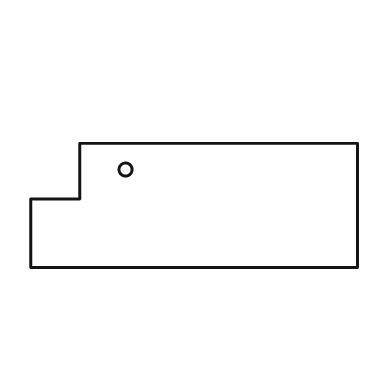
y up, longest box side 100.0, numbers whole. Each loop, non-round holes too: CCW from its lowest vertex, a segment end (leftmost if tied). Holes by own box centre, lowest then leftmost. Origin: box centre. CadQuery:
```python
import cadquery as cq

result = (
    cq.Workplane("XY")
    .moveTo(-50.0, -19.0)
    .lineTo(50.0, -19.0)
    .lineTo(50.0, 19.0)
    .lineTo(-35.0, 19.0)
    .lineTo(-35.0, 2.0)
    .lineTo(-50.0, 2.0)
    .close()
    .moveTo(-21.0, 11.0)
    .circle(2.0)
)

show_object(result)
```